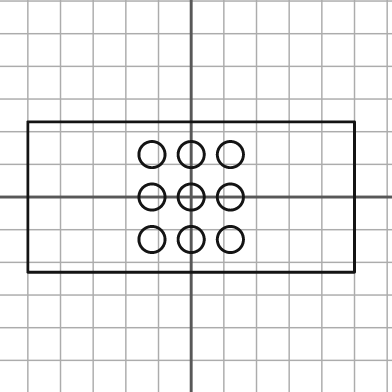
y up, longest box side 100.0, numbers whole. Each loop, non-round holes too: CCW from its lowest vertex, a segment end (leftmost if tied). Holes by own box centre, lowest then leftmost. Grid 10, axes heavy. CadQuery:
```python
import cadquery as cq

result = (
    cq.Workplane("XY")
    .moveTo(-50.0, -23.0)
    .lineTo(50.0, -23.0)
    .lineTo(50.0, 23.0)
    .lineTo(-50.0, 23.0)
    .close()
    .moveTo(-12.0, -13.0)
    .circle(4.0)
    .moveTo(0.0, -13.0)
    .circle(4.0)
    .moveTo(12.0, -13.0)
    .circle(4.0)
    .moveTo(-12.0, 0.0)
    .circle(4.0)
    .moveTo(0.0, 0.0)
    .circle(4.0)
    .moveTo(12.0, 0.0)
    .circle(4.0)
    .moveTo(-12.0, 13.0)
    .circle(4.0)
    .moveTo(0.0, 13.0)
    .circle(4.0)
    .moveTo(12.0, 13.0)
    .circle(4.0)
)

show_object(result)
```